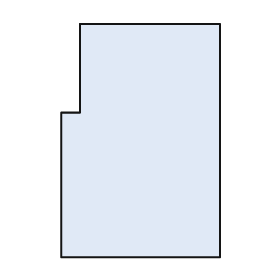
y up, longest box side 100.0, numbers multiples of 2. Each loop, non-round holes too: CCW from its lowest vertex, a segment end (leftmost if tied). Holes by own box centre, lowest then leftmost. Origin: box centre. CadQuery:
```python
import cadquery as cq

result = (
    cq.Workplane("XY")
    .moveTo(-34.0, -50.0)
    .lineTo(34.0, -50.0)
    .lineTo(34.0, 50.0)
    .lineTo(-26.0, 50.0)
    .lineTo(-26.0, 12.0)
    .lineTo(-34.0, 12.0)
    .close()
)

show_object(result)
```